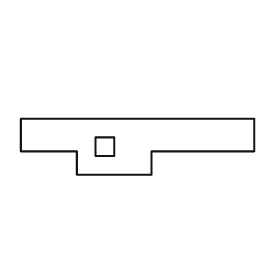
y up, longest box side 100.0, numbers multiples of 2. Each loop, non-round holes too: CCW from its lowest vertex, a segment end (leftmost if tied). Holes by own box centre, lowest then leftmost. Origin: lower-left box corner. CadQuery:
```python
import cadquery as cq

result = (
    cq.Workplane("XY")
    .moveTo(24.0, 0.0)
    .lineTo(56.0, 0.0)
    .lineTo(56.0, 10.0)
    .lineTo(100.0, 10.0)
    .lineTo(100.0, 24.0)
    .lineTo(0.0, 24.0)
    .lineTo(0.0, 10.0)
    .lineTo(24.0, 10.0)
    .close()
    .moveTo(32.0, 8.0)
    .lineTo(40.0, 8.0)
    .lineTo(40.0, 16.0)
    .lineTo(32.0, 16.0)
    .close()
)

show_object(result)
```